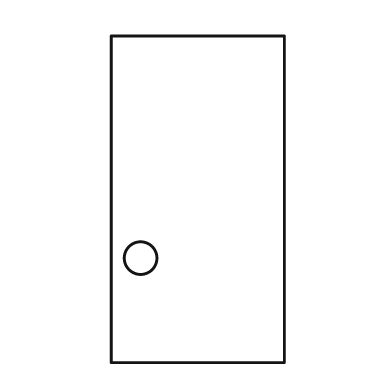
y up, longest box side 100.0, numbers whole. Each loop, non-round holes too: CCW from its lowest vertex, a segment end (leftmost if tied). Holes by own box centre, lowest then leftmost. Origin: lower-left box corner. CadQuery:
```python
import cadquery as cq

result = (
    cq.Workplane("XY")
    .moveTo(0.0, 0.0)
    .lineTo(53.0, 0.0)
    .lineTo(53.0, 100.0)
    .lineTo(0.0, 100.0)
    .close()
    .moveTo(9.0, 32.0)
    .circle(5.0)
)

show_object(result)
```